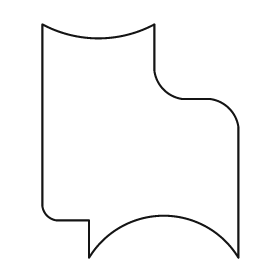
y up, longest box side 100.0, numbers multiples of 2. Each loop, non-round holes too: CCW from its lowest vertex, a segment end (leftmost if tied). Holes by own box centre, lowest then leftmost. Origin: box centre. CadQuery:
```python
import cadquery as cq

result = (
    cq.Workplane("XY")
    .moveTo(-22.0, -50.0)
    .threePointArc((10.0, -32.0), (42.0, -50.0))
    .lineTo(42.0, 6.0)
    .threePointArc((38.0, 14.0), (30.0, 18.0))
    .lineTo(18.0, 18.0)
    .threePointArc((10.0, 22.0), (6.0, 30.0))
    .lineTo(6.0, 50.0)
    .threePointArc((-18.0, 44.0), (-42.0, 50.0))
    .lineTo(-42.0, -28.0)
    .threePointArc((-40.0, -32.0), (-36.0, -34.0))
    .lineTo(-22.0, -34.0)
    .close()
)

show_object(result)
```